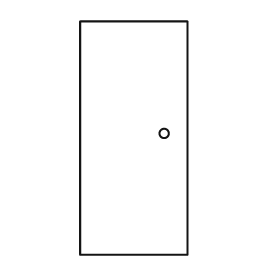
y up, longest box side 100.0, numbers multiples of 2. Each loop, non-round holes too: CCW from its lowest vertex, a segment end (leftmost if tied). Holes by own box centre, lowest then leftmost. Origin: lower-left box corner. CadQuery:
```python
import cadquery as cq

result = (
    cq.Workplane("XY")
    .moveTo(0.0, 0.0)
    .lineTo(46.0, 0.0)
    .lineTo(46.0, 100.0)
    .lineTo(0.0, 100.0)
    .close()
    .moveTo(36.0, 52.0)
    .circle(2.0)
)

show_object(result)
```